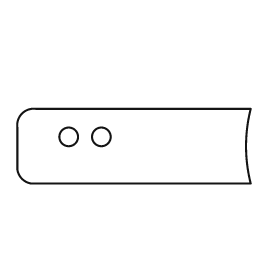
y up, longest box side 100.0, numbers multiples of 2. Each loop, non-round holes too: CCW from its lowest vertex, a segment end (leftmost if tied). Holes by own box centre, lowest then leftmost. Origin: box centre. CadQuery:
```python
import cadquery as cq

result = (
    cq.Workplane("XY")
    .moveTo(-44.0, -16.0)
    .lineTo(50.0, -16.0)
    .threePointArc((48.0, 0.0), (50.0, 16.0))
    .lineTo(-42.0, 16.0)
    .threePointArc((-48.0, 14.0), (-50.0, 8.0))
    .lineTo(-50.0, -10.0)
    .threePointArc((-48.0, -14.0), (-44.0, -16.0))
    .close()
    .moveTo(-28.0, 4.0)
    .circle(4.0)
    .moveTo(-14.0, 4.0)
    .circle(4.0)
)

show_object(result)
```